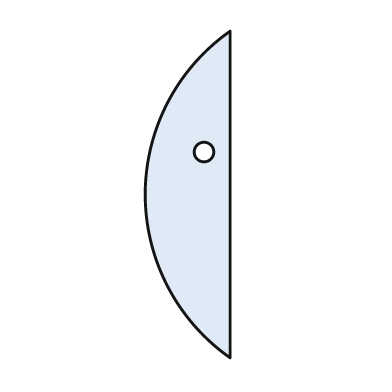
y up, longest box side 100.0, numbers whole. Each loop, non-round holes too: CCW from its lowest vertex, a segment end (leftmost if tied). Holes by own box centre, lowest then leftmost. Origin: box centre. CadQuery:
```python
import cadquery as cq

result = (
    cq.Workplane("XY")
    .moveTo(13.0, -50.0)
    .lineTo(13.0, 50.0)
    .threePointArc((-13.0, 0.0), (13.0, -50.0))
    .close()
    .moveTo(5.0, 13.0)
    .circle(3.0)
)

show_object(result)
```